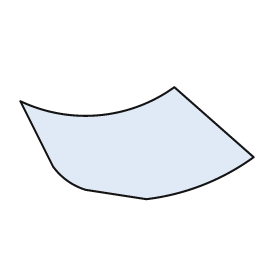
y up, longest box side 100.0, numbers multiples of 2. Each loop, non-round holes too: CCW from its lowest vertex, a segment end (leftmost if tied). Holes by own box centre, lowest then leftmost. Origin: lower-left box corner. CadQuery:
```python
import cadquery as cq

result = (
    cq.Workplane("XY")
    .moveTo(54.0, 0.0)
    .threePointArc((78.0, 6.0), (100.0, 18.0))
    .lineTo(66.0, 48.0)
    .threePointArc((34.0, 36.0), (0.0, 42.0))
    .lineTo(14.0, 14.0)
    .threePointArc((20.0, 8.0), (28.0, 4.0))
    .close()
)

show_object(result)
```